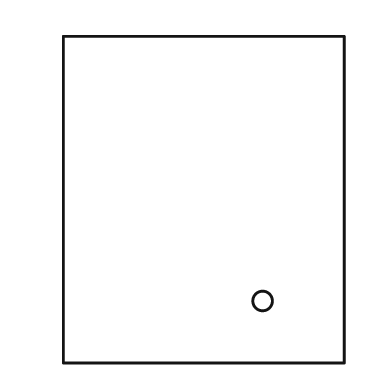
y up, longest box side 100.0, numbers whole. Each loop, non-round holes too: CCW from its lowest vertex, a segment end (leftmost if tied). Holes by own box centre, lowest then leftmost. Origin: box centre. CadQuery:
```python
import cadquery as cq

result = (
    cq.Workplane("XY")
    .moveTo(-43.0, -50.0)
    .lineTo(43.0, -50.0)
    .lineTo(43.0, 50.0)
    .lineTo(-43.0, 50.0)
    .close()
    .moveTo(18.0, -31.0)
    .circle(3.0)
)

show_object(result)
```